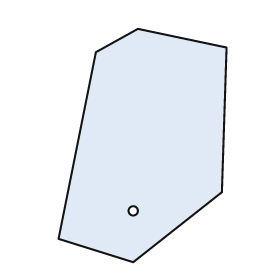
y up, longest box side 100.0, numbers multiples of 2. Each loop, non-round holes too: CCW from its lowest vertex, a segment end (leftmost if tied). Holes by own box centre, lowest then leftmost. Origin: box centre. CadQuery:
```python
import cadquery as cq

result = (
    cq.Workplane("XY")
    .moveTo(-4.0, -50.0)
    .lineTo(34.0, -20.0)
    .lineTo(36.0, 42.0)
    .lineTo(-2.0, 50.0)
    .lineTo(-20.0, 40.0)
    .lineTo(-36.0, -40.0)
    .close()
    .moveTo(-4.0, -28.0)
    .circle(2.0)
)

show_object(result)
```